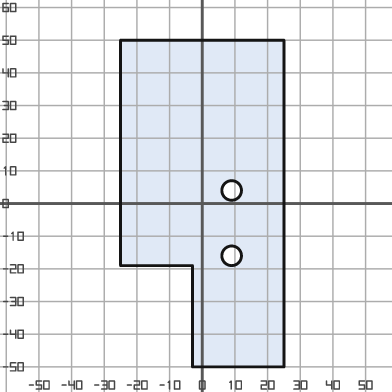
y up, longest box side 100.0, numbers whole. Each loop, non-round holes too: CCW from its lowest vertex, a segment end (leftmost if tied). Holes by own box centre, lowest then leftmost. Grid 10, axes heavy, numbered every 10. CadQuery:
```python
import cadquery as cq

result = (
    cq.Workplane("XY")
    .moveTo(-3.0, -50.0)
    .lineTo(25.0, -50.0)
    .lineTo(25.0, 50.0)
    .lineTo(-25.0, 50.0)
    .lineTo(-25.0, -19.0)
    .lineTo(-3.0, -19.0)
    .close()
    .moveTo(9.0, -16.0)
    .circle(3.0)
    .moveTo(9.0, 4.0)
    .circle(3.0)
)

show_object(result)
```